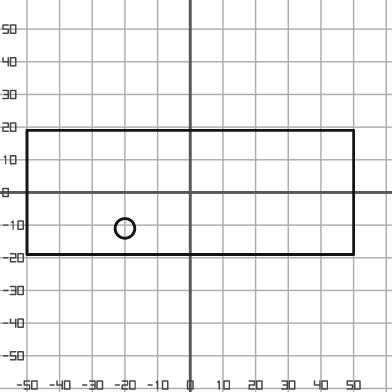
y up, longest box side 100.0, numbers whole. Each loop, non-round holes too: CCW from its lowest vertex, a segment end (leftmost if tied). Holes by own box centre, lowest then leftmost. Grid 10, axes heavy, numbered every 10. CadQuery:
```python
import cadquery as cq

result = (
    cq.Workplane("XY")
    .moveTo(-50.0, -19.0)
    .lineTo(50.0, -19.0)
    .lineTo(50.0, 19.0)
    .lineTo(-50.0, 19.0)
    .close()
    .moveTo(-20.0, -11.0)
    .circle(3.0)
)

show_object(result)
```